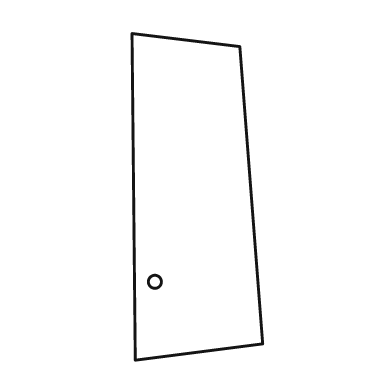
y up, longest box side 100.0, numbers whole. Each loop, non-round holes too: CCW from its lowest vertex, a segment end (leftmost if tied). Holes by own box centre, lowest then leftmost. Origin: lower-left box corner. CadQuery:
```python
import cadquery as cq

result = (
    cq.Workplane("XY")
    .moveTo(1.0, 0.0)
    .lineTo(40.0, 5.0)
    .lineTo(33.0, 96.0)
    .lineTo(0.0, 100.0)
    .close()
    .moveTo(7.0, 24.0)
    .circle(2.0)
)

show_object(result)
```